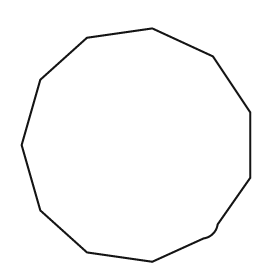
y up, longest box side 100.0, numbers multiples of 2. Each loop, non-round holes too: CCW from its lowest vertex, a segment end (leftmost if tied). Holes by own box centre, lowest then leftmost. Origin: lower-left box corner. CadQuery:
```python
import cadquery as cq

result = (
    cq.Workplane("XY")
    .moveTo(56.0, 0.0)
    .lineTo(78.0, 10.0)
    .threePointArc((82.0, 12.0), (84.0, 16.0))
    .lineTo(98.0, 36.0)
    .lineTo(98.0, 64.0)
    .lineTo(82.0, 88.0)
    .lineTo(56.0, 100.0)
    .lineTo(28.0, 96.0)
    .lineTo(8.0, 78.0)
    .lineTo(0.0, 50.0)
    .lineTo(8.0, 22.0)
    .lineTo(28.0, 4.0)
    .close()
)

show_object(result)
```